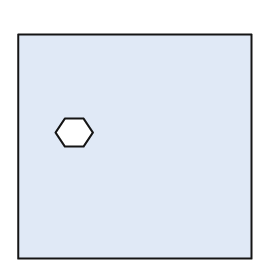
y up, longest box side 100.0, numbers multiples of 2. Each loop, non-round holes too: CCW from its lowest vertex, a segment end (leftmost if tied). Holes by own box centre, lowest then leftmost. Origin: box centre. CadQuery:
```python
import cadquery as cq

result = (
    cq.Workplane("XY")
    .moveTo(-50.0, -48.0)
    .lineTo(50.0, -48.0)
    .lineTo(50.0, 48.0)
    .lineTo(-50.0, 48.0)
    .close()
    .moveTo(-30.0, 0.0)
    .lineTo(-22.0, 0.0)
    .lineTo(-18.0, 6.0)
    .lineTo(-22.0, 12.0)
    .lineTo(-30.0, 12.0)
    .lineTo(-34.0, 6.0)
    .close()
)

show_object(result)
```